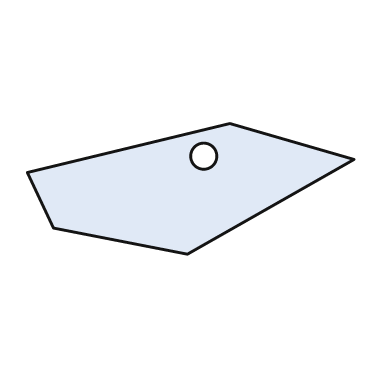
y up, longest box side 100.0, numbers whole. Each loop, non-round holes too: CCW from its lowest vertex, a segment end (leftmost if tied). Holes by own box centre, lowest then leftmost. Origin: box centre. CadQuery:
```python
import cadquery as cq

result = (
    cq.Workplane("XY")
    .moveTo(-1.0, -20.0)
    .lineTo(50.0, 9.0)
    .lineTo(12.0, 20.0)
    .lineTo(-50.0, 5.0)
    .lineTo(-42.0, -12.0)
    .close()
    .moveTo(4.0, 10.0)
    .circle(4.0)
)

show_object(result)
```